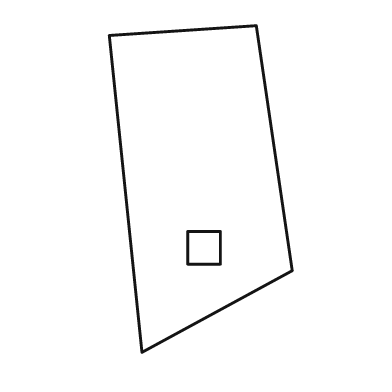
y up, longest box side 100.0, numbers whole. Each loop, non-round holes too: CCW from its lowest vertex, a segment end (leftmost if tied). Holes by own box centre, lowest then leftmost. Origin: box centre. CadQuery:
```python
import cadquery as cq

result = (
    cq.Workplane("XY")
    .moveTo(-18.0, -50.0)
    .lineTo(28.0, -25.0)
    .lineTo(17.0, 50.0)
    .lineTo(-28.0, 47.0)
    .close()
    .moveTo(-4.0, -23.0)
    .lineTo(6.0, -23.0)
    .lineTo(6.0, -13.0)
    .lineTo(-4.0, -13.0)
    .close()
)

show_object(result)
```